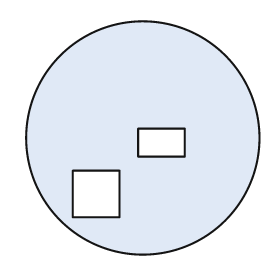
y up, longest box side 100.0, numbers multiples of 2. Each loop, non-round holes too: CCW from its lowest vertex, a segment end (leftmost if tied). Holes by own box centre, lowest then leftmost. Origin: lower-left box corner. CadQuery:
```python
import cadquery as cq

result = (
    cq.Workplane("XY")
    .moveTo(50.0, 50.0)
    .circle(50.0)
    .moveTo(20.0, 16.0)
    .lineTo(40.0, 16.0)
    .lineTo(40.0, 36.0)
    .lineTo(20.0, 36.0)
    .close()
    .moveTo(48.0, 42.0)
    .lineTo(68.0, 42.0)
    .lineTo(68.0, 54.0)
    .lineTo(48.0, 54.0)
    .close()
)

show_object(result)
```